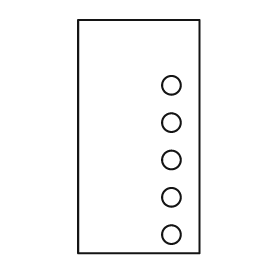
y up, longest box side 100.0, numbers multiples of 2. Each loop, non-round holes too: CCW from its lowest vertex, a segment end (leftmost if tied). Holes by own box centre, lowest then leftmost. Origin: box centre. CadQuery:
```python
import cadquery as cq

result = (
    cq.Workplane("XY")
    .moveTo(-26.0, -50.0)
    .lineTo(26.0, -50.0)
    .lineTo(26.0, 50.0)
    .lineTo(-26.0, 50.0)
    .close()
    .moveTo(14.0, -42.0)
    .circle(4.0)
    .moveTo(14.0, -26.0)
    .circle(4.0)
    .moveTo(14.0, -10.0)
    .circle(4.0)
    .moveTo(14.0, 6.0)
    .circle(4.0)
    .moveTo(14.0, 22.0)
    .circle(4.0)
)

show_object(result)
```